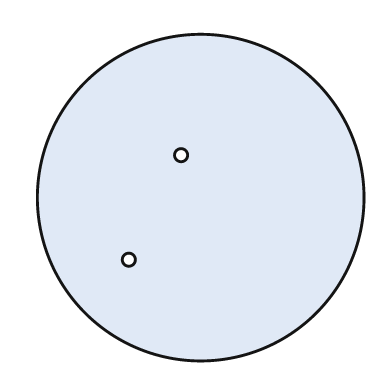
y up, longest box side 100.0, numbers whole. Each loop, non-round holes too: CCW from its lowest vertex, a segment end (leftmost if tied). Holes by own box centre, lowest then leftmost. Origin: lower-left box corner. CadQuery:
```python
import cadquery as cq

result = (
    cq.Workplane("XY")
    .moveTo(50.0, 50.0)
    .circle(50.0)
    .moveTo(28.0, 31.0)
    .circle(2.0)
    .moveTo(44.0, 63.0)
    .circle(2.0)
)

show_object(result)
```